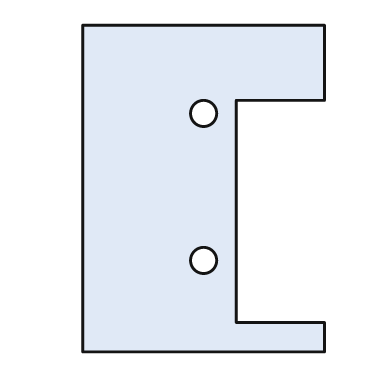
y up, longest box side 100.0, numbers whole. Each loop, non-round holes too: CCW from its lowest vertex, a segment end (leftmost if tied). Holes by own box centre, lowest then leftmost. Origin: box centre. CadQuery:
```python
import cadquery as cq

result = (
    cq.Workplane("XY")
    .moveTo(-37.0, -50.0)
    .lineTo(37.0, -50.0)
    .lineTo(37.0, -41.0)
    .lineTo(10.0, -41.0)
    .lineTo(10.0, 27.0)
    .lineTo(37.0, 27.0)
    .lineTo(37.0, 50.0)
    .lineTo(-37.0, 50.0)
    .close()
    .moveTo(0.0, -22.0)
    .circle(4.0)
    .moveTo(0.0, 23.0)
    .circle(4.0)
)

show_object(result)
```